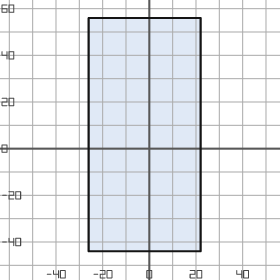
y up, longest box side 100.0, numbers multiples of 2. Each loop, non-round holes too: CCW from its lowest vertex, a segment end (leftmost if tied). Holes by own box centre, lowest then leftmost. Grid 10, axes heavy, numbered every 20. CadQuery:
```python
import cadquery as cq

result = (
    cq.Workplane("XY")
    .moveTo(-26.0, -44.0)
    .lineTo(22.0, -44.0)
    .lineTo(22.0, 56.0)
    .lineTo(-26.0, 56.0)
    .close()
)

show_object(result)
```